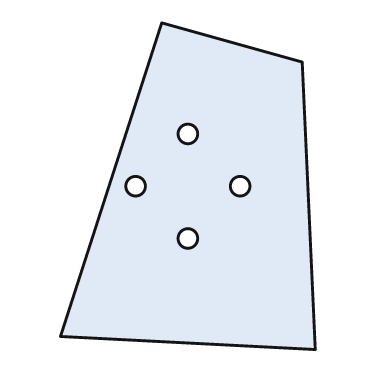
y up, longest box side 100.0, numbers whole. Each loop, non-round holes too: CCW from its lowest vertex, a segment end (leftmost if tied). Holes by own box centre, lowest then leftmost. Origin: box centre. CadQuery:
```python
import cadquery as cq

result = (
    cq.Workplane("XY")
    .moveTo(39.0, -50.0)
    .lineTo(35.0, 38.0)
    .lineTo(-8.0, 50.0)
    .lineTo(-39.0, -46.0)
    .close()
    .moveTo(0.0, -16.0)
    .circle(3.0)
    .moveTo(-16.0, 0.0)
    .circle(3.0)
    .moveTo(16.0, 0.0)
    .circle(3.0)
    .moveTo(0.0, 16.0)
    .circle(3.0)
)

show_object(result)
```